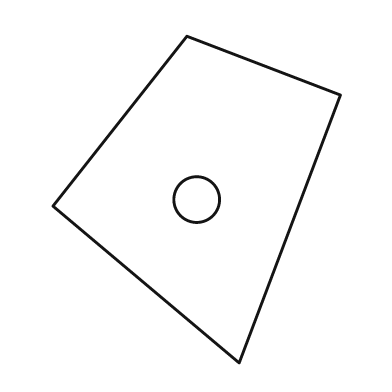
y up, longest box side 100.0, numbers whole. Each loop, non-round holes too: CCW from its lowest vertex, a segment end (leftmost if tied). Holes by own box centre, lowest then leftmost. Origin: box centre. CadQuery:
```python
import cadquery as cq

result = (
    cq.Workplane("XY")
    .moveTo(13.0, -50.0)
    .lineTo(44.0, 32.0)
    .lineTo(-3.0, 50.0)
    .lineTo(-44.0, -2.0)
    .close()
    .moveTo(0.0, 0.0)
    .circle(7.0)
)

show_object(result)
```